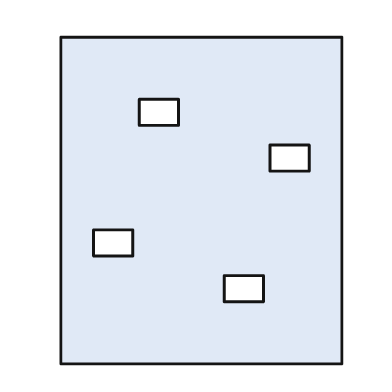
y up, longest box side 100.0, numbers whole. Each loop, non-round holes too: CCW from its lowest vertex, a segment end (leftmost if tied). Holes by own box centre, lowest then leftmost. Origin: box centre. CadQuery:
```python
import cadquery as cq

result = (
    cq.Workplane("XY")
    .moveTo(-43.0, -50.0)
    .lineTo(43.0, -50.0)
    .lineTo(43.0, 50.0)
    .lineTo(-43.0, 50.0)
    .close()
    .moveTo(7.0, -31.0)
    .lineTo(19.0, -31.0)
    .lineTo(19.0, -23.0)
    .lineTo(7.0, -23.0)
    .close()
    .moveTo(-33.0, -17.0)
    .lineTo(-21.0, -17.0)
    .lineTo(-21.0, -9.0)
    .lineTo(-33.0, -9.0)
    .close()
    .moveTo(21.0, 9.0)
    .lineTo(33.0, 9.0)
    .lineTo(33.0, 17.0)
    .lineTo(21.0, 17.0)
    .close()
    .moveTo(-19.0, 23.0)
    .lineTo(-7.0, 23.0)
    .lineTo(-7.0, 31.0)
    .lineTo(-19.0, 31.0)
    .close()
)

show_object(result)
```